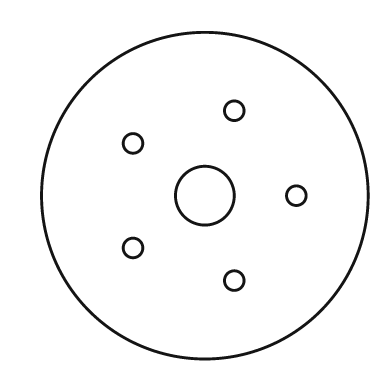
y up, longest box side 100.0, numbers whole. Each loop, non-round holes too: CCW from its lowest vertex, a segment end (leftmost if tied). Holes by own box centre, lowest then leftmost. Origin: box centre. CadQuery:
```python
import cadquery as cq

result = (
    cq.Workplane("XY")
    .moveTo(0.0, 0.0)
    .circle(50.0)
    .moveTo(9.0, -26.0)
    .circle(3.0)
    .moveTo(-22.0, -16.0)
    .circle(3.0)
    .moveTo(0.0, 0.0)
    .circle(9.0)
    .moveTo(28.0, 0.0)
    .circle(3.0)
    .moveTo(-22.0, 16.0)
    .circle(3.0)
    .moveTo(9.0, 26.0)
    .circle(3.0)
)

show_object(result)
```